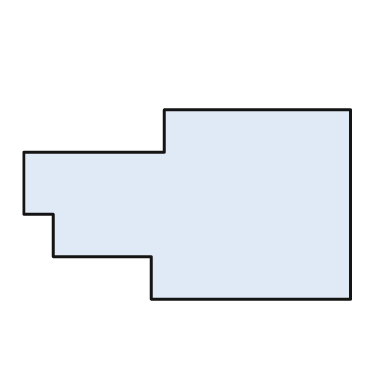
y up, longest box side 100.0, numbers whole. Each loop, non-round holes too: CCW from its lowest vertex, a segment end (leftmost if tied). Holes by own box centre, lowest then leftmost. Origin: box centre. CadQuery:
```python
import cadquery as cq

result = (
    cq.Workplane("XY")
    .moveTo(-11.0, -29.0)
    .lineTo(50.0, -29.0)
    .lineTo(50.0, 29.0)
    .lineTo(-7.0, 29.0)
    .lineTo(-7.0, 16.0)
    .lineTo(-50.0, 16.0)
    .lineTo(-50.0, -3.0)
    .lineTo(-41.0, -3.0)
    .lineTo(-41.0, -16.0)
    .lineTo(-11.0, -16.0)
    .close()
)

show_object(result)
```